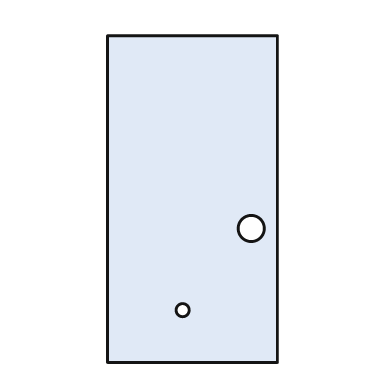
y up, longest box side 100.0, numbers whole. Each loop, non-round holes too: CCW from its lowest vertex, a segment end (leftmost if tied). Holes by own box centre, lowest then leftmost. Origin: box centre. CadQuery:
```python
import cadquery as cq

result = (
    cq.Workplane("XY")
    .moveTo(-26.0, -50.0)
    .lineTo(26.0, -50.0)
    .lineTo(26.0, 50.0)
    .lineTo(-26.0, 50.0)
    .close()
    .moveTo(-3.0, -34.0)
    .circle(2.0)
    .moveTo(18.0, -9.0)
    .circle(4.0)
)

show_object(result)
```